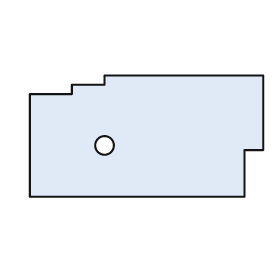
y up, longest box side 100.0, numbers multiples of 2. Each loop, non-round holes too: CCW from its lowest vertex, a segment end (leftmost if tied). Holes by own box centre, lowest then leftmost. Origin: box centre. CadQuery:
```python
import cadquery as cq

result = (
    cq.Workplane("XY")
    .moveTo(-50.0, -26.0)
    .lineTo(42.0, -26.0)
    .lineTo(42.0, -6.0)
    .lineTo(50.0, -6.0)
    .lineTo(50.0, 26.0)
    .lineTo(-18.0, 26.0)
    .lineTo(-18.0, 22.0)
    .lineTo(-32.0, 22.0)
    .lineTo(-32.0, 18.0)
    .lineTo(-50.0, 18.0)
    .close()
    .moveTo(-18.0, -4.0)
    .circle(4.0)
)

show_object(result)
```